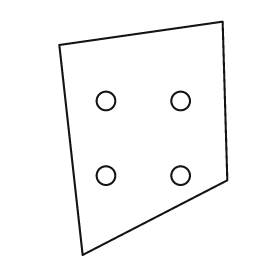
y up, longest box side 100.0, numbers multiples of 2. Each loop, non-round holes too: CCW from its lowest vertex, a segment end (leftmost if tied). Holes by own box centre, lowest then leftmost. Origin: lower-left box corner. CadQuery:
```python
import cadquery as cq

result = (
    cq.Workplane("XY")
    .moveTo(10.0, 0.0)
    .lineTo(72.0, 32.0)
    .lineTo(70.0, 100.0)
    .lineTo(0.0, 90.0)
    .close()
    .moveTo(20.0, 34.0)
    .circle(4.0)
    .moveTo(52.0, 34.0)
    .circle(4.0)
    .moveTo(20.0, 66.0)
    .circle(4.0)
    .moveTo(52.0, 66.0)
    .circle(4.0)
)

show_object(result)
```